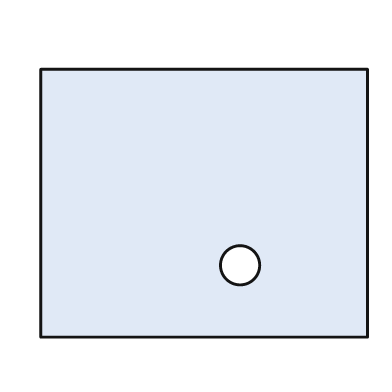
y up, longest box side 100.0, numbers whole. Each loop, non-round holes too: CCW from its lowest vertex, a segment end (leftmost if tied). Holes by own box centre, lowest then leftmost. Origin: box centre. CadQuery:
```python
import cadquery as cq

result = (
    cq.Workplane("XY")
    .moveTo(-50.0, -41.0)
    .lineTo(50.0, -41.0)
    .lineTo(50.0, 41.0)
    .lineTo(-50.0, 41.0)
    .close()
    .moveTo(11.0, -19.0)
    .circle(6.0)
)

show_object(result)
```